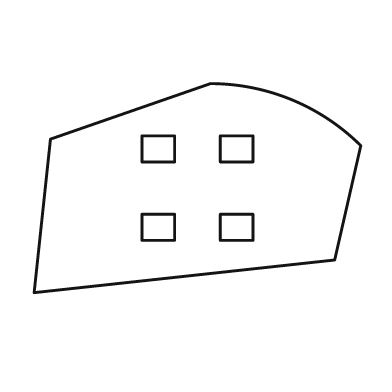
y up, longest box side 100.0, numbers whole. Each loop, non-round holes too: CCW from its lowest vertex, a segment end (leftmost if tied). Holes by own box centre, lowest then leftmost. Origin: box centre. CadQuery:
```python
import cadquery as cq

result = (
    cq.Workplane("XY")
    .moveTo(-50.0, -32.0)
    .lineTo(42.0, -22.0)
    .lineTo(50.0, 13.0)
    .threePointArc((29.0, 27.0), (4.0, 32.0))
    .lineTo(-45.0, 15.0)
    .close()
    .moveTo(-17.0, -16.0)
    .lineTo(-7.0, -16.0)
    .lineTo(-7.0, -8.0)
    .lineTo(-17.0, -8.0)
    .close()
    .moveTo(7.0, -16.0)
    .lineTo(17.0, -16.0)
    .lineTo(17.0, -8.0)
    .lineTo(7.0, -8.0)
    .close()
    .moveTo(-17.0, 8.0)
    .lineTo(-7.0, 8.0)
    .lineTo(-7.0, 16.0)
    .lineTo(-17.0, 16.0)
    .close()
    .moveTo(7.0, 8.0)
    .lineTo(17.0, 8.0)
    .lineTo(17.0, 16.0)
    .lineTo(7.0, 16.0)
    .close()
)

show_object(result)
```